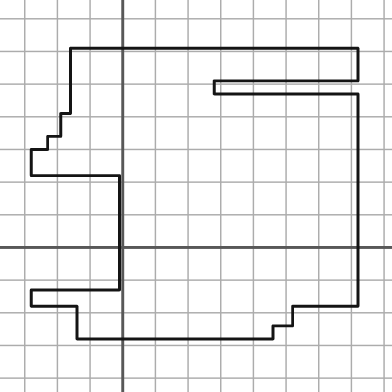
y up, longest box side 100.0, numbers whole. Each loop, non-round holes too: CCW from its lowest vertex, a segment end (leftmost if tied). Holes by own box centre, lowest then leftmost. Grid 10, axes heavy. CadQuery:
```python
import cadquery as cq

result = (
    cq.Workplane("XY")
    .moveTo(-14.0, -28.0)
    .lineTo(46.0, -28.0)
    .lineTo(46.0, -24.0)
    .lineTo(52.0, -24.0)
    .lineTo(52.0, -18.0)
    .lineTo(72.0, -18.0)
    .lineTo(72.0, 47.0)
    .lineTo(28.0, 47.0)
    .lineTo(28.0, 51.0)
    .lineTo(72.0, 51.0)
    .lineTo(72.0, 61.0)
    .lineTo(-16.0, 61.0)
    .lineTo(-16.0, 41.0)
    .lineTo(-19.0, 41.0)
    .lineTo(-19.0, 34.0)
    .lineTo(-23.0, 34.0)
    .lineTo(-23.0, 30.0)
    .lineTo(-28.0, 30.0)
    .lineTo(-28.0, 22.0)
    .lineTo(-1.0, 22.0)
    .lineTo(-1.0, -13.0)
    .lineTo(-28.0, -13.0)
    .lineTo(-28.0, -18.0)
    .lineTo(-14.0, -18.0)
    .close()
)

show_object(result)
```